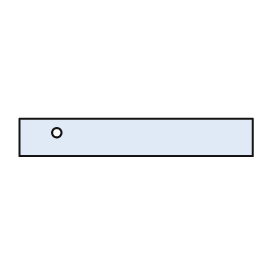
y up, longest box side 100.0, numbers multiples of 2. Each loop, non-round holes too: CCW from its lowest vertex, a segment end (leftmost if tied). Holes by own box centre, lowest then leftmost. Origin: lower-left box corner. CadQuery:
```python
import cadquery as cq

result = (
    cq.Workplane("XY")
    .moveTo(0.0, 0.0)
    .lineTo(100.0, 0.0)
    .lineTo(100.0, 16.0)
    .lineTo(0.0, 16.0)
    .close()
    .moveTo(16.0, 10.0)
    .circle(2.0)
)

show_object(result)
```